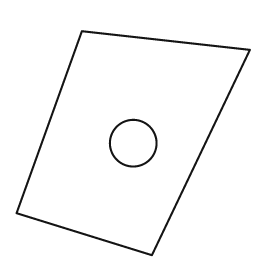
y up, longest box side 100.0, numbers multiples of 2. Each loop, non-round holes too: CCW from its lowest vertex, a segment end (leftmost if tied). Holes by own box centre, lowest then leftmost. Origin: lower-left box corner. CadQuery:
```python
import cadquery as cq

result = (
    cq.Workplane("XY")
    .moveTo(58.0, 0.0)
    .lineTo(100.0, 88.0)
    .lineTo(28.0, 96.0)
    .lineTo(0.0, 18.0)
    .close()
    .moveTo(50.0, 48.0)
    .circle(10.0)
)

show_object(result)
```